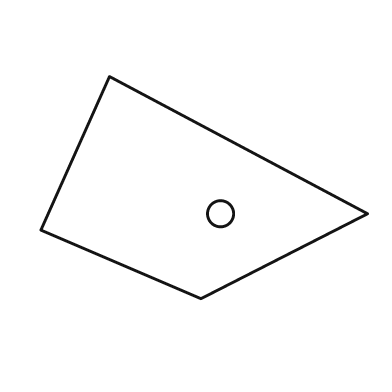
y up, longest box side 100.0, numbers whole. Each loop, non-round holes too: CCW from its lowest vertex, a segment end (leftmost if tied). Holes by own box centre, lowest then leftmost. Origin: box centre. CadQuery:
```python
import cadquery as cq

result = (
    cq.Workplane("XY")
    .moveTo(-1.0, -34.0)
    .lineTo(50.0, -8.0)
    .lineTo(-29.0, 34.0)
    .lineTo(-50.0, -13.0)
    .close()
    .moveTo(5.0, -8.0)
    .circle(4.0)
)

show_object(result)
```